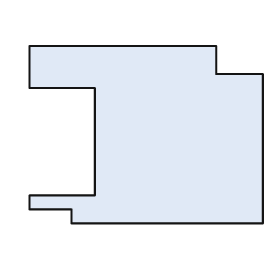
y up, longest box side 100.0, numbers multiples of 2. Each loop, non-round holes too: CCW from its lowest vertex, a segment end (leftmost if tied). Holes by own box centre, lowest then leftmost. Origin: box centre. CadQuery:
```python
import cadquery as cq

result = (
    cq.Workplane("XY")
    .moveTo(-32.0, -38.0)
    .lineTo(50.0, -38.0)
    .lineTo(50.0, 26.0)
    .lineTo(30.0, 26.0)
    .lineTo(30.0, 38.0)
    .lineTo(-50.0, 38.0)
    .lineTo(-50.0, 20.0)
    .lineTo(-22.0, 20.0)
    .lineTo(-22.0, -26.0)
    .lineTo(-50.0, -26.0)
    .lineTo(-50.0, -32.0)
    .lineTo(-32.0, -32.0)
    .close()
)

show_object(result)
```